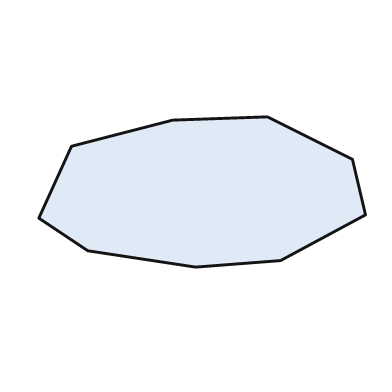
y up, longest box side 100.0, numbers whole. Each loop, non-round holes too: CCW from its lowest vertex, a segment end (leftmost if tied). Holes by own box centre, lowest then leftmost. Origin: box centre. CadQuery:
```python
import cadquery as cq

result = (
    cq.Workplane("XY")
    .moveTo(-2.0, -23.0)
    .lineTo(24.0, -21.0)
    .lineTo(50.0, -7.0)
    .lineTo(46.0, 10.0)
    .lineTo(20.0, 23.0)
    .lineTo(-9.0, 22.0)
    .lineTo(-40.0, 14.0)
    .lineTo(-50.0, -8.0)
    .lineTo(-35.0, -18.0)
    .close()
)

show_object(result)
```